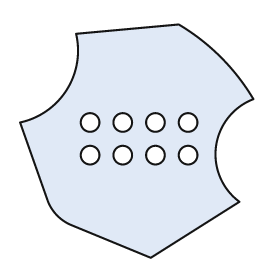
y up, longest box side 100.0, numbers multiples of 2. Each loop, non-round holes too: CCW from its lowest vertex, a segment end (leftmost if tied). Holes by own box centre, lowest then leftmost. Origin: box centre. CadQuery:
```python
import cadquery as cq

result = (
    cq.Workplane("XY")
    .moveTo(6.0, -50.0)
    .lineTo(44.0, -26.0)
    .threePointArc((34.0, -2.0), (50.0, 18.0))
    .threePointArc((36.0, 36.0), (18.0, 50.0))
    .lineTo(-26.0, 46.0)
    .threePointArc((-30.0, 22.0), (-50.0, 8.0))
    .lineTo(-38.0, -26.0)
    .threePointArc((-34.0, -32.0), (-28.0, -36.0))
    .close()
    .moveTo(-20.0, -6.0)
    .circle(4.0)
    .moveTo(-6.0, -6.0)
    .circle(4.0)
    .moveTo(8.0, -6.0)
    .circle(4.0)
    .moveTo(22.0, -6.0)
    .circle(4.0)
    .moveTo(-20.0, 8.0)
    .circle(4.0)
    .moveTo(-6.0, 8.0)
    .circle(4.0)
    .moveTo(8.0, 8.0)
    .circle(4.0)
    .moveTo(22.0, 8.0)
    .circle(4.0)
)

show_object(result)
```